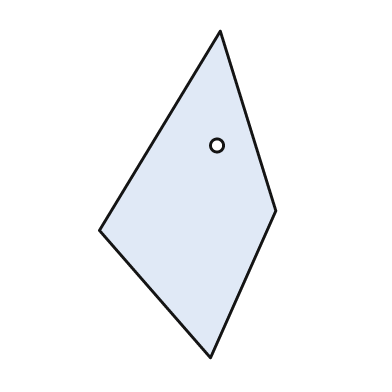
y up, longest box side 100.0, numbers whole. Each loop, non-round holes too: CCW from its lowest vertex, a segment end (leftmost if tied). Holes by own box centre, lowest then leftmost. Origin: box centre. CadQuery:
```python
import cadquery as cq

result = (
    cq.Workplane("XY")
    .moveTo(7.0, -50.0)
    .lineTo(27.0, -5.0)
    .lineTo(10.0, 50.0)
    .lineTo(-27.0, -11.0)
    .close()
    .moveTo(9.0, 15.0)
    .circle(2.0)
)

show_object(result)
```